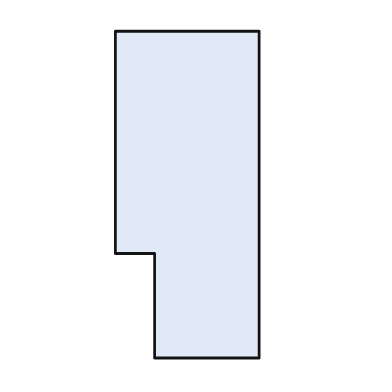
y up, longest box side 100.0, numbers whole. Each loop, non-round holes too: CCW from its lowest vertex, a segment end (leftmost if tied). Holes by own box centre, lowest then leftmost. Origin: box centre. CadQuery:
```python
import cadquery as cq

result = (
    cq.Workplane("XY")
    .moveTo(-10.0, -50.0)
    .lineTo(22.0, -50.0)
    .lineTo(22.0, 50.0)
    .lineTo(-22.0, 50.0)
    .lineTo(-22.0, -18.0)
    .lineTo(-10.0, -18.0)
    .close()
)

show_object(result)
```